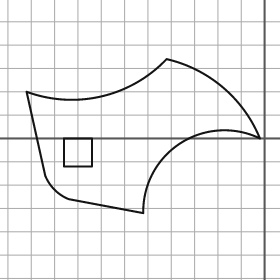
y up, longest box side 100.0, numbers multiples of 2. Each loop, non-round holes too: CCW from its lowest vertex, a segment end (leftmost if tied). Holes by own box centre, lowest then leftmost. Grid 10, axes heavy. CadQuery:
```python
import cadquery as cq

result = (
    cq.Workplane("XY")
    .moveTo(-52.0, -32.0)
    .threePointArc((-36.0, -2.0), (-2.0, 0.0))
    .threePointArc((-18.0, 22.0), (-42.0, 34.0))
    .threePointArc((-70.0, 18.0), (-102.0, 20.0))
    .lineTo(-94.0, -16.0)
    .threePointArc((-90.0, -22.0), (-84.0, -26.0))
    .close()
    .moveTo(-86.0, -12.0)
    .lineTo(-74.0, -12.0)
    .lineTo(-74.0, 0.0)
    .lineTo(-86.0, 0.0)
    .close()
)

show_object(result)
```